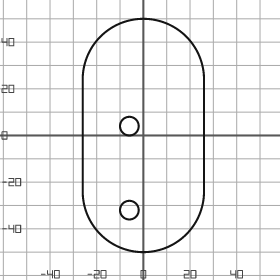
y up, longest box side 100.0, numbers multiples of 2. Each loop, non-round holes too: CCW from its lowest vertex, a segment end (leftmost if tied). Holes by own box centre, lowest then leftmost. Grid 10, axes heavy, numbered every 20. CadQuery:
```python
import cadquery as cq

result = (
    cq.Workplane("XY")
    .moveTo(-26.0, -24.0)
    .threePointArc((0.0, -50.0), (26.0, -24.0))
    .lineTo(26.0, 24.0)
    .threePointArc((0.0, 50.0), (-26.0, 24.0))
    .close()
    .moveTo(-6.0, -32.0)
    .circle(4.0)
    .moveTo(-6.0, 4.0)
    .circle(4.0)
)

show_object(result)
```